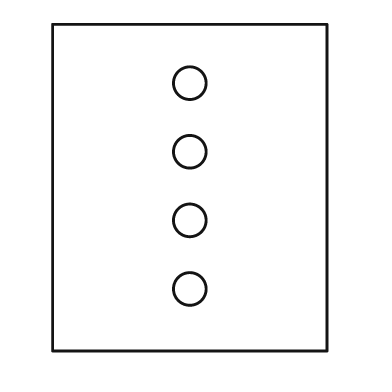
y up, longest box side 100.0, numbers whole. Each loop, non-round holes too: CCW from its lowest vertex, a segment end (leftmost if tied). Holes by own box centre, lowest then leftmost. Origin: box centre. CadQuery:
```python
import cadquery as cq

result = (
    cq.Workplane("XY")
    .moveTo(-42.0, -50.0)
    .lineTo(42.0, -50.0)
    .lineTo(42.0, 50.0)
    .lineTo(-42.0, 50.0)
    .close()
    .moveTo(0.0, -31.0)
    .circle(5.0)
    .moveTo(0.0, -10.0)
    .circle(5.0)
    .moveTo(0.0, 11.0)
    .circle(5.0)
    .moveTo(0.0, 32.0)
    .circle(5.0)
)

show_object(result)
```